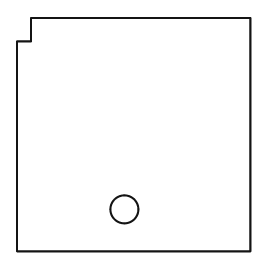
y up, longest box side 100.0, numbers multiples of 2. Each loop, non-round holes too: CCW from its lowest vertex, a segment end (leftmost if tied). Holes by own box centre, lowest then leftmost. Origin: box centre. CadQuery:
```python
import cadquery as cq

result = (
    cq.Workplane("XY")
    .moveTo(-50.0, -50.0)
    .lineTo(50.0, -50.0)
    .lineTo(50.0, 50.0)
    .lineTo(-44.0, 50.0)
    .lineTo(-44.0, 40.0)
    .lineTo(-50.0, 40.0)
    .close()
    .moveTo(-4.0, -32.0)
    .circle(6.0)
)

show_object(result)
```